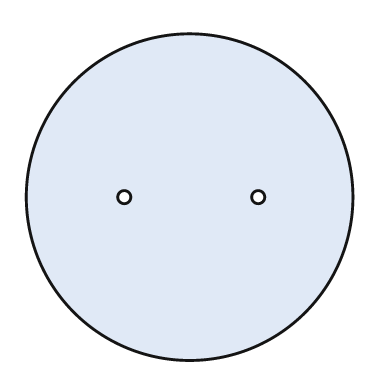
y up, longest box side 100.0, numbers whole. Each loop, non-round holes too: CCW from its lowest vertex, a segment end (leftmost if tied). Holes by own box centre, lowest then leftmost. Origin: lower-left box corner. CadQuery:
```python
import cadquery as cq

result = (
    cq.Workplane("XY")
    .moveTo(50.0, 50.0)
    .circle(50.0)
    .moveTo(30.0, 50.0)
    .circle(2.0)
    .moveTo(71.0, 50.0)
    .circle(2.0)
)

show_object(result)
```